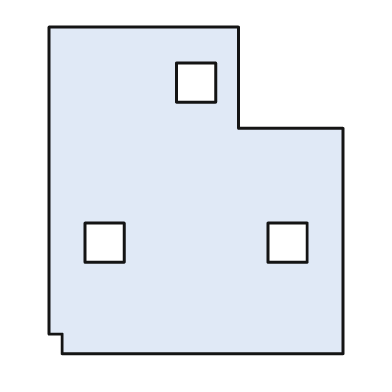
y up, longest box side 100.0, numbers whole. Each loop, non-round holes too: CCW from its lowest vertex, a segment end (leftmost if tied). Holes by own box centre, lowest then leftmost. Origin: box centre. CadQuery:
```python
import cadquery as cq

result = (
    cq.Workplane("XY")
    .moveTo(-41.0, -50.0)
    .lineTo(45.0, -50.0)
    .lineTo(45.0, 19.0)
    .lineTo(13.0, 19.0)
    .lineTo(13.0, 50.0)
    .lineTo(-45.0, 50.0)
    .lineTo(-45.0, -44.0)
    .lineTo(-41.0, -44.0)
    .close()
    .moveTo(-34.0, -22.0)
    .lineTo(-22.0, -22.0)
    .lineTo(-22.0, -10.0)
    .lineTo(-34.0, -10.0)
    .close()
    .moveTo(22.0, -22.0)
    .lineTo(34.0, -22.0)
    .lineTo(34.0, -10.0)
    .lineTo(22.0, -10.0)
    .close()
    .moveTo(-6.0, 27.0)
    .lineTo(6.0, 27.0)
    .lineTo(6.0, 39.0)
    .lineTo(-6.0, 39.0)
    .close()
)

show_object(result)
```